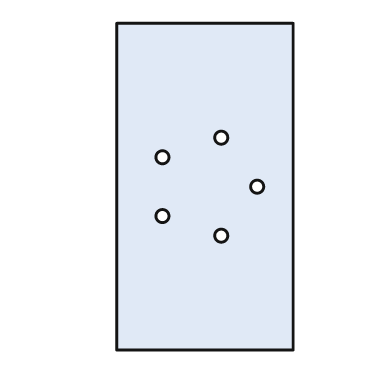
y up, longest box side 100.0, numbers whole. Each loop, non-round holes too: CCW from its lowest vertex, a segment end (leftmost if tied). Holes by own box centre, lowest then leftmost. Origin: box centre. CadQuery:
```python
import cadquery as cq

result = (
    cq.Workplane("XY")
    .moveTo(-27.0, -50.0)
    .lineTo(27.0, -50.0)
    .lineTo(27.0, 50.0)
    .lineTo(-27.0, 50.0)
    .close()
    .moveTo(5.0, -15.0)
    .circle(2.0)
    .moveTo(-13.0, -9.0)
    .circle(2.0)
    .moveTo(16.0, 0.0)
    .circle(2.0)
    .moveTo(-13.0, 9.0)
    .circle(2.0)
    .moveTo(5.0, 15.0)
    .circle(2.0)
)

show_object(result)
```